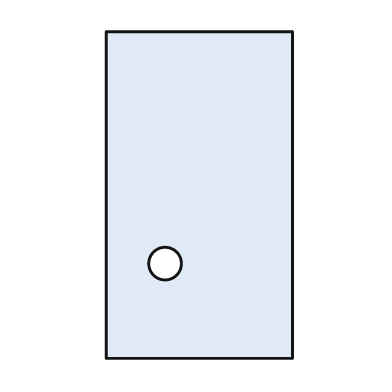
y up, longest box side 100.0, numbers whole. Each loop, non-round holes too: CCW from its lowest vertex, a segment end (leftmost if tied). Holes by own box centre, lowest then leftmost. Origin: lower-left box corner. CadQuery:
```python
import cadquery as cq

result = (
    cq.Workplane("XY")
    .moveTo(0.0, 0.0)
    .lineTo(57.0, 0.0)
    .lineTo(57.0, 100.0)
    .lineTo(0.0, 100.0)
    .close()
    .moveTo(18.0, 29.0)
    .circle(5.0)
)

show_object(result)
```